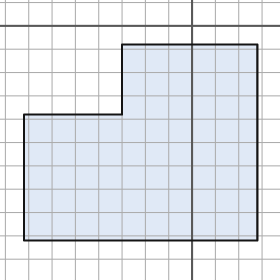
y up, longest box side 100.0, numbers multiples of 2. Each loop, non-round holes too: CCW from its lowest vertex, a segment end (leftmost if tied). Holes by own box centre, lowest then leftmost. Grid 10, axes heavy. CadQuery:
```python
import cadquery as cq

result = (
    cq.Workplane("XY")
    .moveTo(-72.0, -92.0)
    .lineTo(28.0, -92.0)
    .lineTo(28.0, -8.0)
    .lineTo(-30.0, -8.0)
    .lineTo(-30.0, -38.0)
    .lineTo(-72.0, -38.0)
    .close()
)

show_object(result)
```